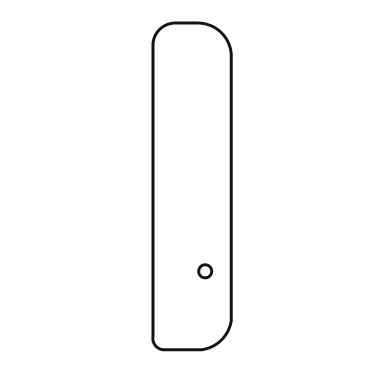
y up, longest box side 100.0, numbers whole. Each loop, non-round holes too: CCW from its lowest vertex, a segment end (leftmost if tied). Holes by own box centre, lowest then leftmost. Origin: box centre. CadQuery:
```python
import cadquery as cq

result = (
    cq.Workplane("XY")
    .moveTo(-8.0, -50.0)
    .lineTo(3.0, -50.0)
    .threePointArc((9.0, -47.0), (12.0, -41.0))
    .lineTo(12.0, 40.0)
    .threePointArc((9.0, 47.0), (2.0, 50.0))
    .lineTo(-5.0, 50.0)
    .threePointArc((-10.0, 48.0), (-12.0, 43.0))
    .lineTo(-12.0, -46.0)
    .threePointArc((-11.0, -49.0), (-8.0, -50.0))
    .close()
    .moveTo(4.0, -26.0)
    .circle(2.0)
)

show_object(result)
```